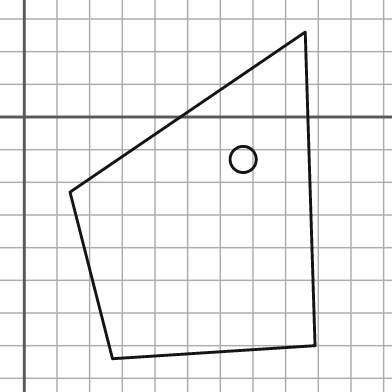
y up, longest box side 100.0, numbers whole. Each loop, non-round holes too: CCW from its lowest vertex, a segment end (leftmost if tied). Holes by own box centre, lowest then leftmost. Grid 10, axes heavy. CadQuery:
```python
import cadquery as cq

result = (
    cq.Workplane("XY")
    .moveTo(27.0, -74.0)
    .lineTo(89.0, -70.0)
    .lineTo(86.0, 26.0)
    .lineTo(14.0, -23.0)
    .close()
    .moveTo(67.0, -13.0)
    .circle(4.0)
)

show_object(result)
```